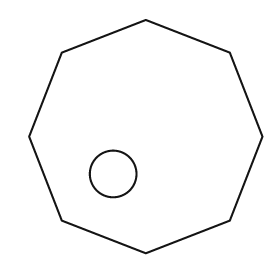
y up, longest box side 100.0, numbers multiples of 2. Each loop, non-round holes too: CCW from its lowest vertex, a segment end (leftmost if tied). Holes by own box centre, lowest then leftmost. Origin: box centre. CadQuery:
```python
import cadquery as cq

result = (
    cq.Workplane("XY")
    .moveTo(0.0, -50.0)
    .lineTo(36.0, -36.0)
    .lineTo(50.0, 0.0)
    .lineTo(36.0, 36.0)
    .lineTo(0.0, 50.0)
    .lineTo(-36.0, 36.0)
    .lineTo(-50.0, 0.0)
    .lineTo(-36.0, -36.0)
    .close()
    .moveTo(-14.0, -16.0)
    .circle(10.0)
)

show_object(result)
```